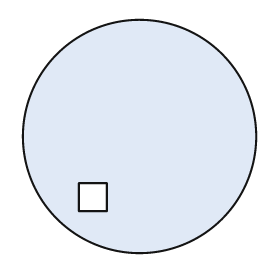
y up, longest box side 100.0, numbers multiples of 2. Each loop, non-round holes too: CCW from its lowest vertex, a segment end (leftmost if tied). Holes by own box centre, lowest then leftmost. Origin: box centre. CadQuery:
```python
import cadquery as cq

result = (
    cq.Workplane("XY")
    .moveTo(0.0, 0.0)
    .circle(50.0)
    .moveTo(-26.0, -32.0)
    .lineTo(-14.0, -32.0)
    .lineTo(-14.0, -20.0)
    .lineTo(-26.0, -20.0)
    .close()
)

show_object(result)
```